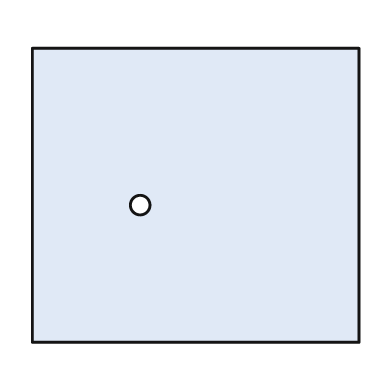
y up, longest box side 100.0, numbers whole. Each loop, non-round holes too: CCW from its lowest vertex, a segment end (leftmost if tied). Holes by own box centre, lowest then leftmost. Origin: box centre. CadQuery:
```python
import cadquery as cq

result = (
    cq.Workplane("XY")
    .moveTo(-50.0, -45.0)
    .lineTo(50.0, -45.0)
    .lineTo(50.0, 45.0)
    .lineTo(-50.0, 45.0)
    .close()
    .moveTo(-17.0, -3.0)
    .circle(3.0)
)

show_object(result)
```